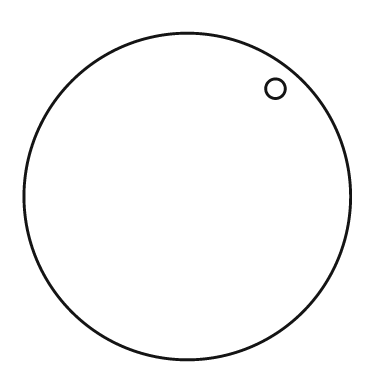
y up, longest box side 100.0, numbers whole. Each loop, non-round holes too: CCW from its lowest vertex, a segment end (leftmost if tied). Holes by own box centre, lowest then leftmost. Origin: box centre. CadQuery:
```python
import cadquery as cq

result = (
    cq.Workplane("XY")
    .moveTo(0.0, 0.0)
    .circle(50.0)
    .moveTo(27.0, 33.0)
    .circle(3.0)
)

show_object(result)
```